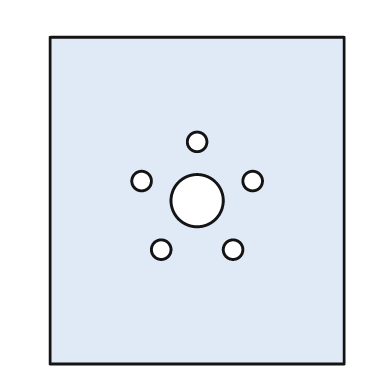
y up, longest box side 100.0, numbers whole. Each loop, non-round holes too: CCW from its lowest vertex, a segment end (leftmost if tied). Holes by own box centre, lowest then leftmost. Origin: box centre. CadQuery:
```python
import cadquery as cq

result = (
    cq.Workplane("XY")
    .moveTo(-45.0, -50.0)
    .lineTo(45.0, -50.0)
    .lineTo(45.0, 50.0)
    .lineTo(-45.0, 50.0)
    .close()
    .moveTo(-11.0, -15.0)
    .circle(3.0)
    .moveTo(11.0, -15.0)
    .circle(3.0)
    .moveTo(0.0, 0.0)
    .circle(8.0)
    .moveTo(-17.0, 6.0)
    .circle(3.0)
    .moveTo(17.0, 6.0)
    .circle(3.0)
    .moveTo(0.0, 18.0)
    .circle(3.0)
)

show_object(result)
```